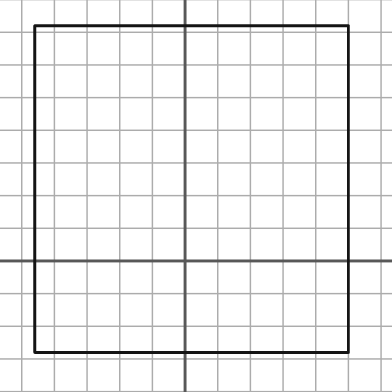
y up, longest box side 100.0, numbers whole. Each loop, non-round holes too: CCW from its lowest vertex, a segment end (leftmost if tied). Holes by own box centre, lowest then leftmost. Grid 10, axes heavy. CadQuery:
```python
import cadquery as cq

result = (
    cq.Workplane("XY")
    .moveTo(-46.0, -28.0)
    .lineTo(50.0, -28.0)
    .lineTo(50.0, 72.0)
    .lineTo(-46.0, 72.0)
    .close()
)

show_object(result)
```